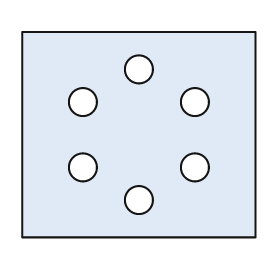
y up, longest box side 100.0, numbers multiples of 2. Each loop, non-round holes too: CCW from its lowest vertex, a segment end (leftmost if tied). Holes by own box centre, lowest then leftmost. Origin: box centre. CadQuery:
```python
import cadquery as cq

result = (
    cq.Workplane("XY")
    .moveTo(-50.0, -44.0)
    .lineTo(50.0, -44.0)
    .lineTo(50.0, 44.0)
    .lineTo(-50.0, 44.0)
    .close()
    .moveTo(0.0, -28.0)
    .circle(6.0)
    .moveTo(-24.0, -14.0)
    .circle(6.0)
    .moveTo(24.0, -14.0)
    .circle(6.0)
    .moveTo(-24.0, 14.0)
    .circle(6.0)
    .moveTo(24.0, 14.0)
    .circle(6.0)
    .moveTo(0.0, 28.0)
    .circle(6.0)
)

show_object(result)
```